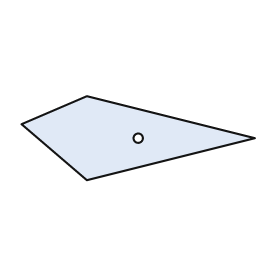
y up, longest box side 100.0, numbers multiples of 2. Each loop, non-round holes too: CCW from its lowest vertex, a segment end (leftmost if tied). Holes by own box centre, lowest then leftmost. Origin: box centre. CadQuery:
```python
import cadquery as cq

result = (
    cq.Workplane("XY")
    .moveTo(-22.0, -18.0)
    .lineTo(50.0, 0.0)
    .lineTo(-22.0, 18.0)
    .lineTo(-50.0, 6.0)
    .close()
    .moveTo(0.0, 0.0)
    .circle(2.0)
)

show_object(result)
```